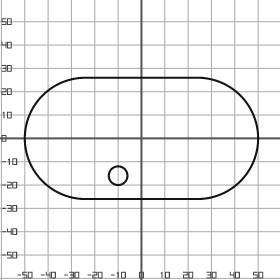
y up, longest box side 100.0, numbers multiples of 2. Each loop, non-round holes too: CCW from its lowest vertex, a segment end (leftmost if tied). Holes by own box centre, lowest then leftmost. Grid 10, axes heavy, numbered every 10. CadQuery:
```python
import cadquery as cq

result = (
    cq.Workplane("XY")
    .moveTo(-24.0, -26.0)
    .lineTo(24.0, -26.0)
    .threePointArc((50.0, 0.0), (24.0, 26.0))
    .lineTo(-24.0, 26.0)
    .threePointArc((-50.0, 0.0), (-24.0, -26.0))
    .close()
    .moveTo(-10.0, -16.0)
    .circle(4.0)
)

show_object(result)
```